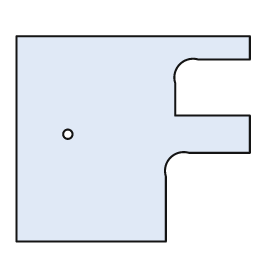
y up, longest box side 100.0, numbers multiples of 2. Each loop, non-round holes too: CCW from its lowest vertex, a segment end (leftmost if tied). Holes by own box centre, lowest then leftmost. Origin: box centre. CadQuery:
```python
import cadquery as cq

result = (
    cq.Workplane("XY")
    .moveTo(-50.0, -44.0)
    .lineTo(14.0, -44.0)
    .lineTo(14.0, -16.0)
    .threePointArc((16.0, -8.0), (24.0, -6.0))
    .lineTo(50.0, -6.0)
    .lineTo(50.0, 10.0)
    .lineTo(18.0, 10.0)
    .lineTo(18.0, 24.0)
    .threePointArc((20.0, 32.0), (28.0, 34.0))
    .lineTo(50.0, 34.0)
    .lineTo(50.0, 44.0)
    .lineTo(-50.0, 44.0)
    .close()
    .moveTo(-28.0, 2.0)
    .circle(2.0)
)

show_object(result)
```